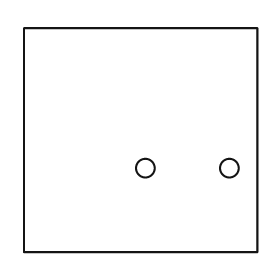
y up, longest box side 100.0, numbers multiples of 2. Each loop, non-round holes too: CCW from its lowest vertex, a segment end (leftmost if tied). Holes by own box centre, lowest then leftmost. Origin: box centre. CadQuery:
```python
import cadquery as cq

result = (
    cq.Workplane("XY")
    .moveTo(-50.0, -48.0)
    .lineTo(50.0, -48.0)
    .lineTo(50.0, 48.0)
    .lineTo(-50.0, 48.0)
    .close()
    .moveTo(2.0, -12.0)
    .circle(4.0)
    .moveTo(38.0, -12.0)
    .circle(4.0)
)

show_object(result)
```